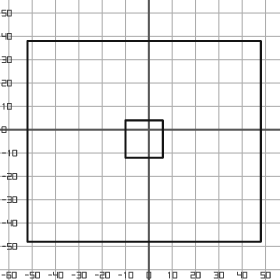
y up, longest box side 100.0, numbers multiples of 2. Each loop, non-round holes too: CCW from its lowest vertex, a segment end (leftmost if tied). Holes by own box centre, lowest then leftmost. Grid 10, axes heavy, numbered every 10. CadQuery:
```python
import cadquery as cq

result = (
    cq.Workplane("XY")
    .moveTo(-52.0, -48.0)
    .lineTo(48.0, -48.0)
    .lineTo(48.0, 38.0)
    .lineTo(-52.0, 38.0)
    .close()
    .moveTo(-10.0, -12.0)
    .lineTo(6.0, -12.0)
    .lineTo(6.0, 4.0)
    .lineTo(-10.0, 4.0)
    .close()
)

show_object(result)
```